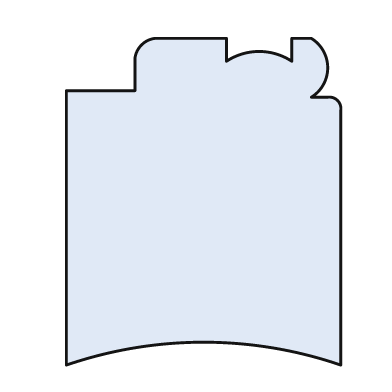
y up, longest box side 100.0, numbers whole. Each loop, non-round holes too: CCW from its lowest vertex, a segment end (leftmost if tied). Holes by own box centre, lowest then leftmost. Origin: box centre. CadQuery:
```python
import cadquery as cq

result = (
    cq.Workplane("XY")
    .moveTo(-42.0, -50.0)
    .threePointArc((0.0, -43.0), (42.0, -50.0))
    .lineTo(42.0, 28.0)
    .threePointArc((41.0, 31.0), (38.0, 32.0))
    .lineTo(33.0, 32.0)
    .threePointArc((38.0, 41.0), (33.0, 50.0))
    .lineTo(27.0, 50.0)
    .lineTo(27.0, 43.0)
    .threePointArc((17.0, 46.0), (7.0, 43.0))
    .lineTo(7.0, 50.0)
    .lineTo(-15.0, 50.0)
    .threePointArc((-19.0, 48.0), (-21.0, 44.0))
    .lineTo(-21.0, 34.0)
    .lineTo(-42.0, 34.0)
    .close()
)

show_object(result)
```